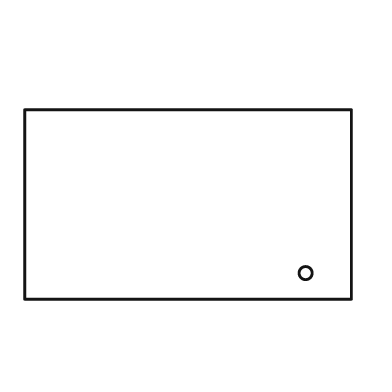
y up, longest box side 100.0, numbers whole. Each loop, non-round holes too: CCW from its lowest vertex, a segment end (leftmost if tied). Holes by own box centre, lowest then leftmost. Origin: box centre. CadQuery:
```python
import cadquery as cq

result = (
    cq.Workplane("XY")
    .moveTo(-50.0, -29.0)
    .lineTo(50.0, -29.0)
    .lineTo(50.0, 29.0)
    .lineTo(-50.0, 29.0)
    .close()
    .moveTo(36.0, -21.0)
    .circle(2.0)
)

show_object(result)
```